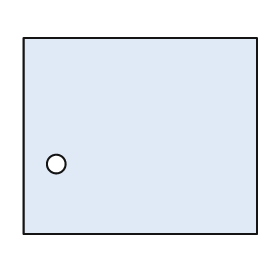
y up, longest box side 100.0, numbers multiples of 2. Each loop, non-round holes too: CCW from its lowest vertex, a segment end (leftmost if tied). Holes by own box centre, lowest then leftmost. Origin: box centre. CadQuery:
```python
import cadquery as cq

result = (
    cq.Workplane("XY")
    .moveTo(-50.0, -42.0)
    .lineTo(50.0, -42.0)
    .lineTo(50.0, 42.0)
    .lineTo(-50.0, 42.0)
    .close()
    .moveTo(-36.0, -12.0)
    .circle(4.0)
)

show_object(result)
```